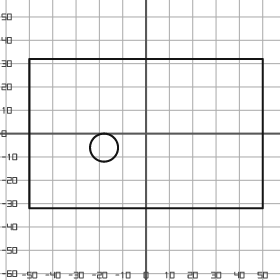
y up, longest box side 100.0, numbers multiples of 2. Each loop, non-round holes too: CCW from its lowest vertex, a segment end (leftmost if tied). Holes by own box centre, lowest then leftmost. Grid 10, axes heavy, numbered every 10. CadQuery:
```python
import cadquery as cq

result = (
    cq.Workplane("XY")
    .moveTo(-50.0, -32.0)
    .lineTo(50.0, -32.0)
    .lineTo(50.0, 32.0)
    .lineTo(-50.0, 32.0)
    .close()
    .moveTo(-18.0, -6.0)
    .circle(6.0)
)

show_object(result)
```